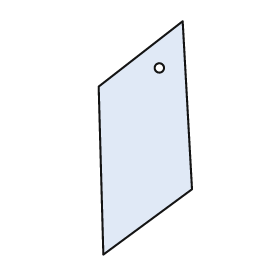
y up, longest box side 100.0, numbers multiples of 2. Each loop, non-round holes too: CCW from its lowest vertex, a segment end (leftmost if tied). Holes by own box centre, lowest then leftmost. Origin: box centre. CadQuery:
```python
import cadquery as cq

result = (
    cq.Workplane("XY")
    .moveTo(-18.0, -50.0)
    .lineTo(20.0, -22.0)
    .lineTo(16.0, 50.0)
    .lineTo(-20.0, 22.0)
    .close()
    .moveTo(6.0, 30.0)
    .circle(2.0)
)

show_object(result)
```